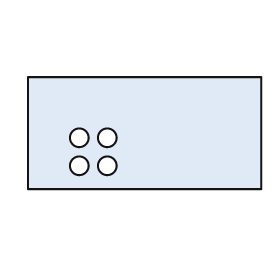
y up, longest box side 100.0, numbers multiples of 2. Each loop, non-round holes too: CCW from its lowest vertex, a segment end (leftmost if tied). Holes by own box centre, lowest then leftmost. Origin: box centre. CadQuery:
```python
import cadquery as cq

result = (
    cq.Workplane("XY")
    .moveTo(-50.0, -24.0)
    .lineTo(50.0, -24.0)
    .lineTo(50.0, 24.0)
    .lineTo(-50.0, 24.0)
    .close()
    .moveTo(-28.0, -14.0)
    .circle(4.0)
    .moveTo(-16.0, -14.0)
    .circle(4.0)
    .moveTo(-28.0, -2.0)
    .circle(4.0)
    .moveTo(-16.0, -2.0)
    .circle(4.0)
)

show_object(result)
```